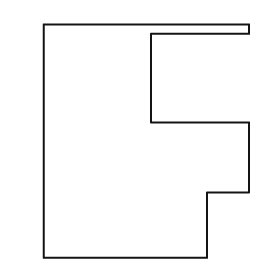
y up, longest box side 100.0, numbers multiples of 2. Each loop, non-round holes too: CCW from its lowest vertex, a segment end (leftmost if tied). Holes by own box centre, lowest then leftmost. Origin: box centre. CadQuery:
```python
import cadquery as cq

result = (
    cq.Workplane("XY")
    .moveTo(-44.0, -50.0)
    .lineTo(26.0, -50.0)
    .lineTo(26.0, -22.0)
    .lineTo(44.0, -22.0)
    .lineTo(44.0, 8.0)
    .lineTo(2.0, 8.0)
    .lineTo(2.0, 46.0)
    .lineTo(44.0, 46.0)
    .lineTo(44.0, 50.0)
    .lineTo(-44.0, 50.0)
    .close()
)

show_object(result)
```